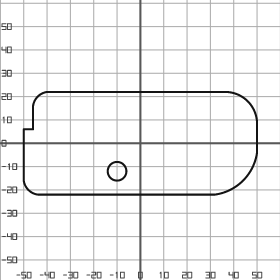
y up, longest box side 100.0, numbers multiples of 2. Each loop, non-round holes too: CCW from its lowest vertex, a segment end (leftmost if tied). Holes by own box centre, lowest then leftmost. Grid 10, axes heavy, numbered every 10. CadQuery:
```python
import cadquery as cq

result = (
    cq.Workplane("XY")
    .moveTo(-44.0, -22.0)
    .lineTo(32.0, -22.0)
    .threePointArc((44.0, -16.0), (50.0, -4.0))
    .lineTo(50.0, 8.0)
    .threePointArc((46.0, 18.0), (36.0, 22.0))
    .lineTo(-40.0, 22.0)
    .threePointArc((-44.0, 20.0), (-46.0, 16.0))
    .lineTo(-46.0, 6.0)
    .lineTo(-50.0, 6.0)
    .lineTo(-50.0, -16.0)
    .threePointArc((-48.0, -20.0), (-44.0, -22.0))
    .close()
    .moveTo(-10.0, -12.0)
    .circle(4.0)
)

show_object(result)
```